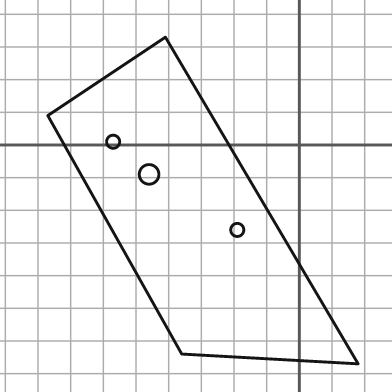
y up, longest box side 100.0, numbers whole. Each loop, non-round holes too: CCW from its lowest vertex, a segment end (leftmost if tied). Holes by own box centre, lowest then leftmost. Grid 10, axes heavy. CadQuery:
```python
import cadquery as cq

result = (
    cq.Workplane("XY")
    .moveTo(18.0, -67.0)
    .lineTo(-41.0, 33.0)
    .lineTo(-77.0, 9.0)
    .lineTo(-36.0, -64.0)
    .close()
    .moveTo(-19.0, -26.0)
    .circle(2.0)
    .moveTo(-46.0, -9.0)
    .circle(3.0)
    .moveTo(-57.0, 1.0)
    .circle(2.0)
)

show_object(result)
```